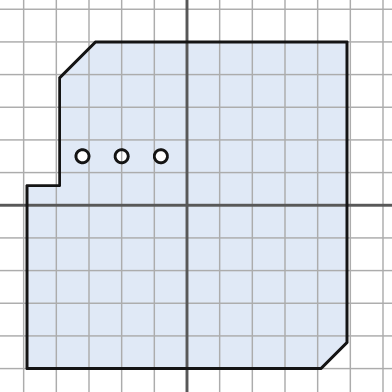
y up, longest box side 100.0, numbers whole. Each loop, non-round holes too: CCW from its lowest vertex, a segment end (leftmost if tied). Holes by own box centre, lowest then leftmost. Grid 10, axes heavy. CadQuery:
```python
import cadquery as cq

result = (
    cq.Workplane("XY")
    .moveTo(-49.0, -50.0)
    .lineTo(41.0, -50.0)
    .lineTo(49.0, -42.0)
    .lineTo(49.0, 50.0)
    .lineTo(-28.0, 50.0)
    .lineTo(-39.0, 39.0)
    .lineTo(-39.0, 6.0)
    .lineTo(-49.0, 6.0)
    .close()
    .moveTo(-32.0, 15.0)
    .circle(2.0)
    .moveTo(-20.0, 15.0)
    .circle(2.0)
    .moveTo(-8.0, 15.0)
    .circle(2.0)
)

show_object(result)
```